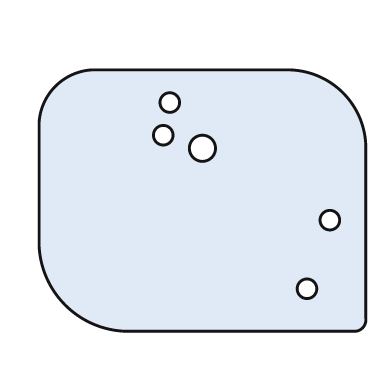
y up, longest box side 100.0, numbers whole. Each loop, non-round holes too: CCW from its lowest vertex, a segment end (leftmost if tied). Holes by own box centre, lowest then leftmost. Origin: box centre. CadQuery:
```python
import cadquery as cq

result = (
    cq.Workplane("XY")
    .moveTo(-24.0, -40.0)
    .lineTo(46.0, -40.0)
    .threePointArc((49.0, -39.0), (50.0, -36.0))
    .lineTo(50.0, 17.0)
    .threePointArc((43.0, 33.0), (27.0, 40.0))
    .lineTo(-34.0, 40.0)
    .threePointArc((-45.0, 35.0), (-50.0, 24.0))
    .lineTo(-50.0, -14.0)
    .threePointArc((-42.0, -32.0), (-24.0, -40.0))
    .close()
    .moveTo(32.0, -27.0)
    .circle(3.0)
    .moveTo(39.0, -6.0)
    .circle(3.0)
    .moveTo(0.0, 16.0)
    .circle(4.0)
    .moveTo(-12.0, 20.0)
    .circle(3.0)
    .moveTo(-10.0, 30.0)
    .circle(3.0)
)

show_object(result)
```